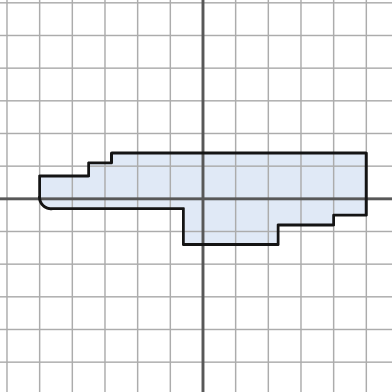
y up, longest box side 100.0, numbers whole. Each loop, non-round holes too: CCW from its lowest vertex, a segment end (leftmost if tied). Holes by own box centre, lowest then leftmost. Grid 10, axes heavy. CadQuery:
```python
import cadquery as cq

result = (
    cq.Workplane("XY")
    .moveTo(-6.0, -14.0)
    .lineTo(23.0, -14.0)
    .lineTo(23.0, -8.0)
    .lineTo(40.0, -8.0)
    .lineTo(40.0, -5.0)
    .lineTo(50.0, -5.0)
    .lineTo(50.0, 14.0)
    .lineTo(-28.0, 14.0)
    .lineTo(-28.0, 11.0)
    .lineTo(-35.0, 11.0)
    .lineTo(-35.0, 7.0)
    .lineTo(-50.0, 7.0)
    .lineTo(-50.0, 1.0)
    .threePointArc((-49.0, -2.0), (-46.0, -3.0))
    .lineTo(-6.0, -3.0)
    .close()
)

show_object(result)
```